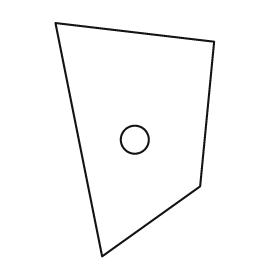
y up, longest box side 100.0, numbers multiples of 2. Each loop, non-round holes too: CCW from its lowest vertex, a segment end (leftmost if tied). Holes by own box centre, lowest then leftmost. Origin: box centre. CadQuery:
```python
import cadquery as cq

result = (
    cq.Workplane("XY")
    .moveTo(-14.0, -50.0)
    .lineTo(28.0, -20.0)
    .lineTo(34.0, 42.0)
    .lineTo(-34.0, 50.0)
    .close()
    .moveTo(0.0, 0.0)
    .circle(6.0)
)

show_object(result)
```